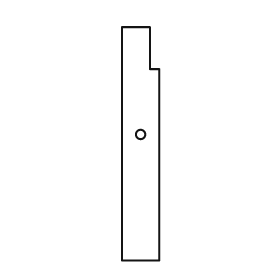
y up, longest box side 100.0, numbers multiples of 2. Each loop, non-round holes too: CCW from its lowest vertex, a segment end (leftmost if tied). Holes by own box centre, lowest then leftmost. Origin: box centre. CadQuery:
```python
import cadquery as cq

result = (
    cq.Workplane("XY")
    .moveTo(-8.0, -50.0)
    .lineTo(8.0, -50.0)
    .lineTo(8.0, 32.0)
    .lineTo(4.0, 32.0)
    .lineTo(4.0, 50.0)
    .lineTo(-8.0, 50.0)
    .close()
    .moveTo(0.0, 4.0)
    .circle(2.0)
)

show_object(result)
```